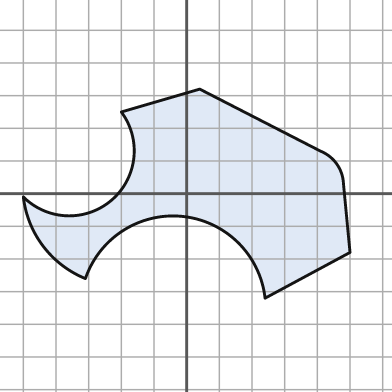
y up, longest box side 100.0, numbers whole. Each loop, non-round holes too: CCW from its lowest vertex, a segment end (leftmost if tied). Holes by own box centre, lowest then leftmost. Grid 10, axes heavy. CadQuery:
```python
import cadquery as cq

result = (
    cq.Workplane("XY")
    .moveTo(24.0, -32.0)
    .lineTo(50.0, -18.0)
    .lineTo(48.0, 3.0)
    .threePointArc((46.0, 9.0), (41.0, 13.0))
    .lineTo(4.0, 32.0)
    .lineTo(-20.0, 25.0)
    .threePointArc((-23.0, -2.0), (-50.0, -1.0))
    .threePointArc((-44.0, -16.0), (-31.0, -26.0))
    .threePointArc((-1.0, -7.0), (24.0, -32.0))
    .close()
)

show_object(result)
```